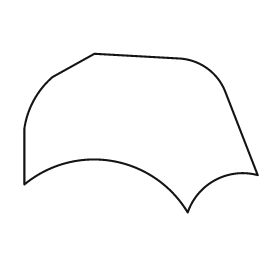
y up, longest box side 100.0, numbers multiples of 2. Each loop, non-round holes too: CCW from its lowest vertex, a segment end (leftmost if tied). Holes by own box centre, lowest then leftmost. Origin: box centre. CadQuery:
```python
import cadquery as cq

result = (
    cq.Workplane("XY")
    .moveTo(20.0, -34.0)
    .threePointArc((32.0, -20.0), (50.0, -18.0))
    .lineTo(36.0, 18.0)
    .threePointArc((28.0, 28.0), (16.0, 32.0))
    .lineTo(-20.0, 34.0)
    .lineTo(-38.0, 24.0)
    .threePointArc((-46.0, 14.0), (-50.0, 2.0))
    .lineTo(-50.0, -22.0)
    .threePointArc((-12.0, -12.0), (20.0, -34.0))
    .close()
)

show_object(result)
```